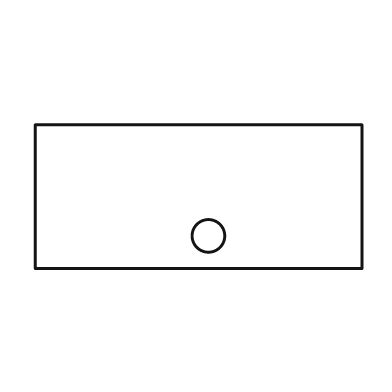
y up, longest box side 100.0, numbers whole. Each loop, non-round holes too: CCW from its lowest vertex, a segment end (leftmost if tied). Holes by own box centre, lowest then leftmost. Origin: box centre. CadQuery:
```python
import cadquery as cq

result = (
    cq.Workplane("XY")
    .moveTo(-50.0, -22.0)
    .lineTo(50.0, -22.0)
    .lineTo(50.0, 22.0)
    .lineTo(-50.0, 22.0)
    .close()
    .moveTo(3.0, -12.0)
    .circle(5.0)
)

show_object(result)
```